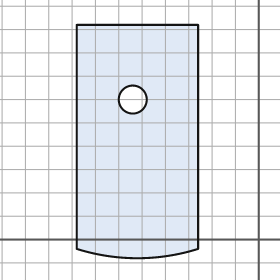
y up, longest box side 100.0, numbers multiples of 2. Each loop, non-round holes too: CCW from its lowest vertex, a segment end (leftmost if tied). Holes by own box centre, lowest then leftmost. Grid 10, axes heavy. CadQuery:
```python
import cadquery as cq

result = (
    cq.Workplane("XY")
    .moveTo(-78.0, -4.0)
    .threePointArc((-52.0, -8.0), (-26.0, -4.0))
    .lineTo(-26.0, 92.0)
    .lineTo(-78.0, 92.0)
    .close()
    .moveTo(-54.0, 60.0)
    .circle(6.0)
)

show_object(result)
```